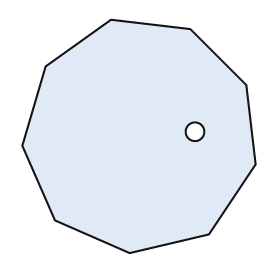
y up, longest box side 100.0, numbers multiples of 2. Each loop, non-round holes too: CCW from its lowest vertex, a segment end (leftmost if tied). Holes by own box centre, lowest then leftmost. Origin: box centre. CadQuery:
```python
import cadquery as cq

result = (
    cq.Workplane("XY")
    .moveTo(-4.0, -50.0)
    .lineTo(30.0, -42.0)
    .lineTo(50.0, -12.0)
    .lineTo(46.0, 22.0)
    .lineTo(22.0, 46.0)
    .lineTo(-12.0, 50.0)
    .lineTo(-40.0, 30.0)
    .lineTo(-50.0, -4.0)
    .lineTo(-36.0, -36.0)
    .close()
    .moveTo(24.0, 2.0)
    .circle(4.0)
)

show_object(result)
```